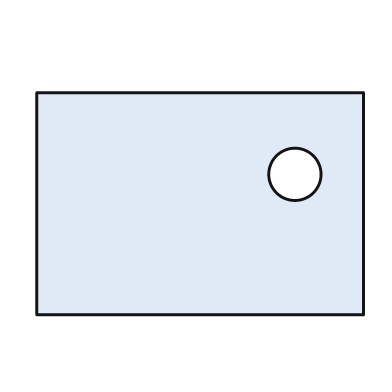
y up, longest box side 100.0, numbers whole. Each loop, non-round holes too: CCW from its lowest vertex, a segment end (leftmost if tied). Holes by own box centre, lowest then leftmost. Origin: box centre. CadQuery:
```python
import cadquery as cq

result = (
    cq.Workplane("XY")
    .moveTo(-50.0, -34.0)
    .lineTo(50.0, -34.0)
    .lineTo(50.0, 34.0)
    .lineTo(-50.0, 34.0)
    .close()
    .moveTo(29.0, 9.0)
    .circle(8.0)
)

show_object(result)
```